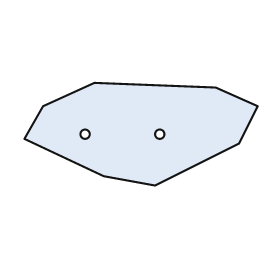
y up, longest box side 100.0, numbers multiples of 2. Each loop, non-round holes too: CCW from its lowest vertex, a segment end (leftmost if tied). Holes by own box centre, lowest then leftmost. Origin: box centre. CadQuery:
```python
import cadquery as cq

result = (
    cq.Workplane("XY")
    .moveTo(6.0, -22.0)
    .lineTo(42.0, -4.0)
    .lineTo(50.0, 12.0)
    .lineTo(32.0, 20.0)
    .lineTo(-20.0, 22.0)
    .lineTo(-42.0, 12.0)
    .lineTo(-50.0, -2.0)
    .lineTo(-16.0, -18.0)
    .close()
    .moveTo(-24.0, 0.0)
    .circle(2.0)
    .moveTo(8.0, 0.0)
    .circle(2.0)
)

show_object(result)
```